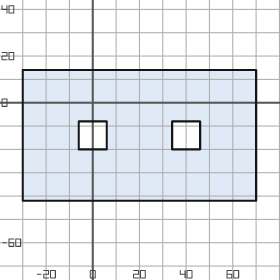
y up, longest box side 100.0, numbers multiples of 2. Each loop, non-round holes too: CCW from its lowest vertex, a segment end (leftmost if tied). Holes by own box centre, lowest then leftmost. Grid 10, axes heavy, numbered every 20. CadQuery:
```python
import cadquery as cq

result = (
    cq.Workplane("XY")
    .moveTo(-30.0, -42.0)
    .lineTo(70.0, -42.0)
    .lineTo(70.0, 14.0)
    .lineTo(-30.0, 14.0)
    .close()
    .moveTo(-6.0, -20.0)
    .lineTo(6.0, -20.0)
    .lineTo(6.0, -8.0)
    .lineTo(-6.0, -8.0)
    .close()
    .moveTo(34.0, -20.0)
    .lineTo(46.0, -20.0)
    .lineTo(46.0, -8.0)
    .lineTo(34.0, -8.0)
    .close()
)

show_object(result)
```